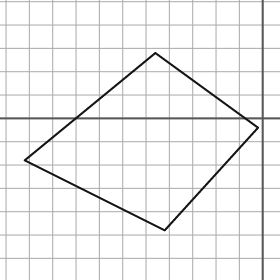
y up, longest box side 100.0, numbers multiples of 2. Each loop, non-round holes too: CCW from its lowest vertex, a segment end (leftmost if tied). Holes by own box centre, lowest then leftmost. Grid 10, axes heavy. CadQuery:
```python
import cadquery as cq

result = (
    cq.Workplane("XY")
    .moveTo(-42.0, -48.0)
    .lineTo(-2.0, -4.0)
    .lineTo(-46.0, 28.0)
    .lineTo(-102.0, -18.0)
    .close()
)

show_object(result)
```